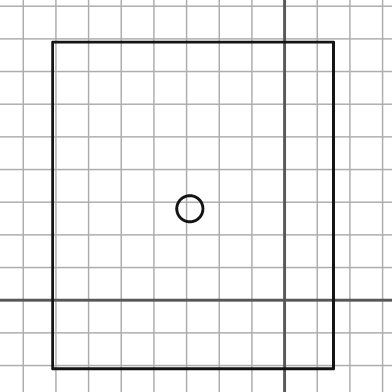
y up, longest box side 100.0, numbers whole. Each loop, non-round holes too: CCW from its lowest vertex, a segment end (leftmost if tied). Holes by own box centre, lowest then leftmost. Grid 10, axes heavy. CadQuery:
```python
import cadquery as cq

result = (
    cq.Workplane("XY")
    .moveTo(-71.0, -21.0)
    .lineTo(15.0, -21.0)
    .lineTo(15.0, 79.0)
    .lineTo(-71.0, 79.0)
    .close()
    .moveTo(-29.0, 28.0)
    .circle(4.0)
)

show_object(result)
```